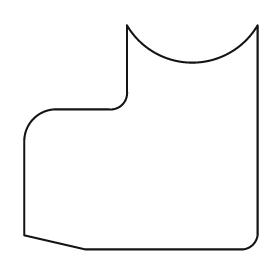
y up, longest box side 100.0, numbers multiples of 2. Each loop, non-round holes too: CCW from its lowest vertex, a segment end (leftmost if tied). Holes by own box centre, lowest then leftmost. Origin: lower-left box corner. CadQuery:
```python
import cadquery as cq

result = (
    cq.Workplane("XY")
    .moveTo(26.0, 0.0)
    .lineTo(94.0, 0.0)
    .threePointArc((98.0, 2.0), (100.0, 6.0))
    .lineTo(100.0, 96.0)
    .threePointArc((72.0, 80.0), (44.0, 96.0))
    .lineTo(44.0, 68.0)
    .threePointArc((42.0, 62.0), (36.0, 60.0))
    .lineTo(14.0, 60.0)
    .threePointArc((4.0, 56.0), (0.0, 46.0))
    .lineTo(0.0, 6.0)
    .close()
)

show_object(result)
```